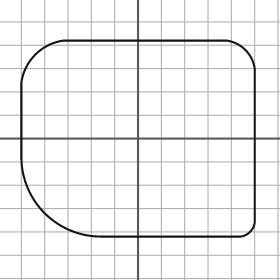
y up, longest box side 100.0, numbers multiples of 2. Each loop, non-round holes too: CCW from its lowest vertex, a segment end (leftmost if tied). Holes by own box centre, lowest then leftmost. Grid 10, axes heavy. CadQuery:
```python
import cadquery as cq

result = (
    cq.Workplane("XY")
    .moveTo(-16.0, -42.0)
    .lineTo(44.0, -42.0)
    .threePointArc((48.0, -40.0), (50.0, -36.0))
    .lineTo(50.0, 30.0)
    .threePointArc((46.0, 38.0), (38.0, 42.0))
    .lineTo(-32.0, 42.0)
    .threePointArc((-44.0, 36.0), (-50.0, 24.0))
    .lineTo(-50.0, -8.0)
    .threePointArc((-40.0, -32.0), (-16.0, -42.0))
    .close()
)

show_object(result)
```